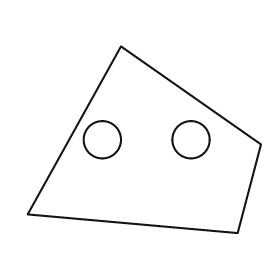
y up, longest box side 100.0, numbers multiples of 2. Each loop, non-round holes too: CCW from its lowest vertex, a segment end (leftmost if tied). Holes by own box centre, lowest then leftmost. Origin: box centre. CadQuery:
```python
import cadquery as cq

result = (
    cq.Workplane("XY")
    .moveTo(40.0, -40.0)
    .lineTo(50.0, -2.0)
    .lineTo(-10.0, 40.0)
    .lineTo(-50.0, -32.0)
    .close()
    .moveTo(-18.0, 0.0)
    .circle(8.0)
    .moveTo(20.0, 0.0)
    .circle(8.0)
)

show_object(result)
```